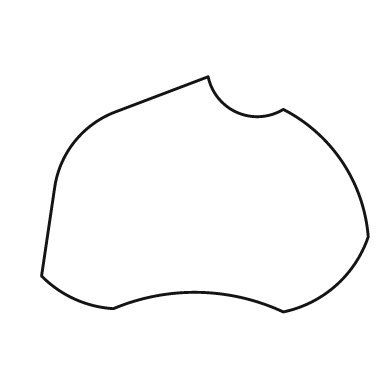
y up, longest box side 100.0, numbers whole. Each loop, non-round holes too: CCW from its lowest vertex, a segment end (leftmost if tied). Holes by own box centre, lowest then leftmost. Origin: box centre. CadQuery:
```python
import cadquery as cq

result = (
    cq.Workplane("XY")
    .moveTo(24.0, -36.0)
    .threePointArc((40.0, -28.0), (50.0, -13.0))
    .threePointArc((42.0, 10.0), (24.0, 26.0))
    .threePointArc((10.0, 25.0), (1.0, 36.0))
    .lineTo(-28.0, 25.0)
    .threePointArc((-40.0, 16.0), (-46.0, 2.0))
    .lineTo(-50.0, -25.0)
    .threePointArc((-40.0, -32.0), (-28.0, -35.0))
    .threePointArc((-2.0, -30.0), (24.0, -36.0))
    .close()
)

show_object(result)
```